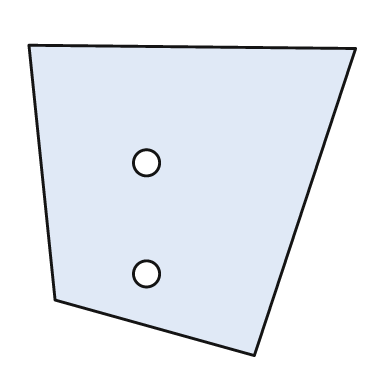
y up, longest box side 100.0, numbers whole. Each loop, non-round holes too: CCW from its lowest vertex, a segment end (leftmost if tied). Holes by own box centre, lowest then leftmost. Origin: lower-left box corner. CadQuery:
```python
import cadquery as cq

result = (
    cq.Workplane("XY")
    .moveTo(69.0, 0.0)
    .lineTo(100.0, 94.0)
    .lineTo(0.0, 95.0)
    .lineTo(8.0, 17.0)
    .close()
    .moveTo(36.0, 25.0)
    .circle(4.0)
    .moveTo(36.0, 59.0)
    .circle(4.0)
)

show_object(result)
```